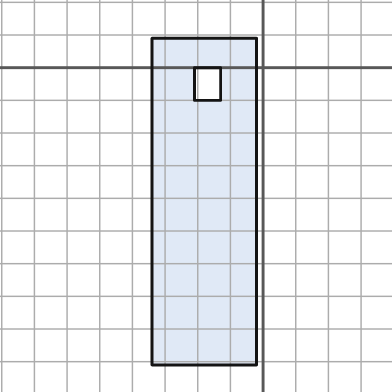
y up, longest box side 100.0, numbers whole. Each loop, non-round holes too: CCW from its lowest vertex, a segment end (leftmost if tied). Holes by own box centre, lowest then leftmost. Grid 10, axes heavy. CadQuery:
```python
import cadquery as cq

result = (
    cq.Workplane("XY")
    .moveTo(-34.0, -91.0)
    .lineTo(-2.0, -91.0)
    .lineTo(-2.0, 9.0)
    .lineTo(-34.0, 9.0)
    .close()
    .moveTo(-21.0, -10.0)
    .lineTo(-13.0, -10.0)
    .lineTo(-13.0, 0.0)
    .lineTo(-21.0, 0.0)
    .close()
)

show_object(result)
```